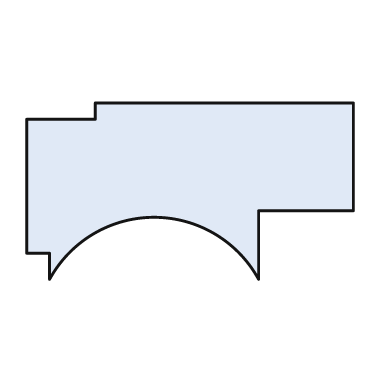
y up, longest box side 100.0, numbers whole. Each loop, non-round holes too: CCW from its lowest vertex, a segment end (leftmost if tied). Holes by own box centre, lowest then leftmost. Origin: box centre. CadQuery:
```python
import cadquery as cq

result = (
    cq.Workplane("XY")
    .moveTo(-43.0, -27.0)
    .threePointArc((-11.0, -8.0), (21.0, -27.0))
    .lineTo(21.0, -6.0)
    .lineTo(50.0, -6.0)
    .lineTo(50.0, 27.0)
    .lineTo(-29.0, 27.0)
    .lineTo(-29.0, 22.0)
    .lineTo(-50.0, 22.0)
    .lineTo(-50.0, -19.0)
    .lineTo(-43.0, -19.0)
    .close()
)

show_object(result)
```